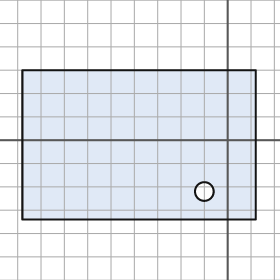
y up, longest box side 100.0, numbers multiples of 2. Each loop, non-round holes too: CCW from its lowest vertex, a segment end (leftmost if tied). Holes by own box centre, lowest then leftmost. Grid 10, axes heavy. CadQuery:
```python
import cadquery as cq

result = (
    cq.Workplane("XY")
    .moveTo(-88.0, -34.0)
    .lineTo(12.0, -34.0)
    .lineTo(12.0, 30.0)
    .lineTo(-88.0, 30.0)
    .close()
    .moveTo(-10.0, -22.0)
    .circle(4.0)
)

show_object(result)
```